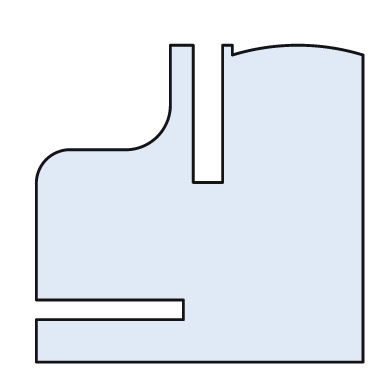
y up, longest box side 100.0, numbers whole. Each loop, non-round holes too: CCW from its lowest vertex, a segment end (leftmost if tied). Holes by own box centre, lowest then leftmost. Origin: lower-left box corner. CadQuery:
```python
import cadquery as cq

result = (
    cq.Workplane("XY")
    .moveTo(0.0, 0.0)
    .lineTo(100.0, 0.0)
    .lineTo(100.0, 94.0)
    .threePointArc((80.0, 97.0), (60.0, 94.0))
    .lineTo(60.0, 97.0)
    .lineTo(57.0, 97.0)
    .lineTo(57.0, 55.0)
    .lineTo(48.0, 55.0)
    .lineTo(48.0, 97.0)
    .lineTo(41.0, 97.0)
    .lineTo(41.0, 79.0)
    .threePointArc((37.0, 69.0), (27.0, 65.0))
    .lineTo(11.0, 65.0)
    .threePointArc((3.0, 62.0), (0.0, 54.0))
    .lineTo(0.0, 19.0)
    .lineTo(45.0, 19.0)
    .lineTo(45.0, 13.0)
    .lineTo(0.0, 13.0)
    .close()
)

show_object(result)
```